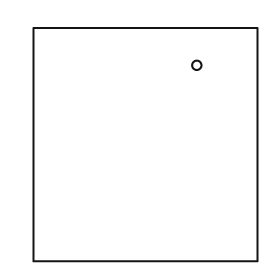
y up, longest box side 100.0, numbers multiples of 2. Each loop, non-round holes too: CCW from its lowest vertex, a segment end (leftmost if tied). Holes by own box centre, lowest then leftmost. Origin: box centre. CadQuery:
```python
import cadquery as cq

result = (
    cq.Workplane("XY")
    .moveTo(-48.0, -50.0)
    .lineTo(48.0, -50.0)
    .lineTo(48.0, 50.0)
    .lineTo(-48.0, 50.0)
    .close()
    .moveTo(22.0, 34.0)
    .circle(2.0)
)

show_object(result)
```